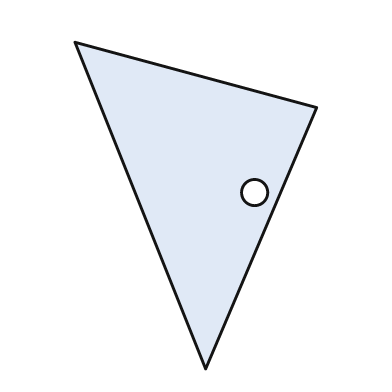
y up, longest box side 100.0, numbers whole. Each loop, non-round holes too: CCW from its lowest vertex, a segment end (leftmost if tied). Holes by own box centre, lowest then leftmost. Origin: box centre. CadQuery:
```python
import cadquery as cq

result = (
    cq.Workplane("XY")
    .moveTo(3.0, -50.0)
    .lineTo(37.0, 30.0)
    .lineTo(-37.0, 50.0)
    .close()
    .moveTo(18.0, 4.0)
    .circle(4.0)
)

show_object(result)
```